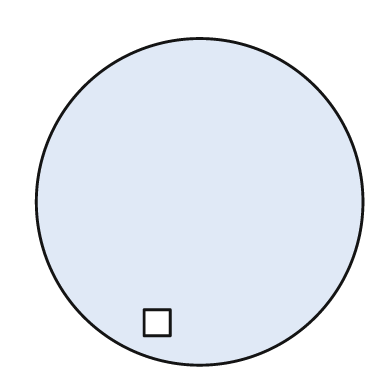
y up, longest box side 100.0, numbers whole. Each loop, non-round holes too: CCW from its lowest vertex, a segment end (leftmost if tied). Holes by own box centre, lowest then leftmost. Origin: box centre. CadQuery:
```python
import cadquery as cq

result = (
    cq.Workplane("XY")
    .moveTo(0.0, 0.0)
    .circle(50.0)
    .moveTo(-17.0, -41.0)
    .lineTo(-9.0, -41.0)
    .lineTo(-9.0, -33.0)
    .lineTo(-17.0, -33.0)
    .close()
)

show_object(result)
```